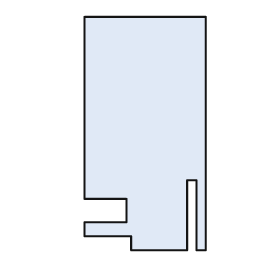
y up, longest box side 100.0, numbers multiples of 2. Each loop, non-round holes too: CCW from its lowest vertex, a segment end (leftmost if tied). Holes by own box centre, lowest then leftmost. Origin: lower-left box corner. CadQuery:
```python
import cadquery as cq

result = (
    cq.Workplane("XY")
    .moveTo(20.0, 0.0)
    .lineTo(44.0, 0.0)
    .lineTo(44.0, 30.0)
    .lineTo(48.0, 30.0)
    .lineTo(48.0, 0.0)
    .lineTo(52.0, 0.0)
    .lineTo(52.0, 100.0)
    .lineTo(0.0, 100.0)
    .lineTo(0.0, 22.0)
    .lineTo(18.0, 22.0)
    .lineTo(18.0, 12.0)
    .lineTo(0.0, 12.0)
    .lineTo(0.0, 6.0)
    .lineTo(20.0, 6.0)
    .close()
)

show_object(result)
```